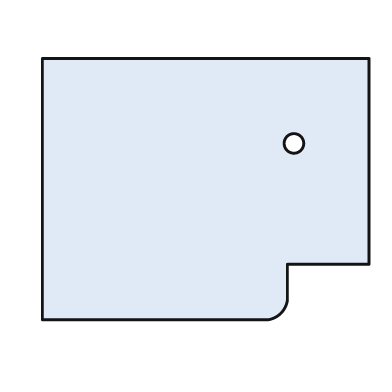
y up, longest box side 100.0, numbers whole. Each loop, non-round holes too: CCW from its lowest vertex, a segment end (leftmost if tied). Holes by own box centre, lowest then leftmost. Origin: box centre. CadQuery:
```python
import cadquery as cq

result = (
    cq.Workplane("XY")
    .moveTo(-50.0, -40.0)
    .lineTo(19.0, -40.0)
    .threePointArc((23.0, -38.0), (25.0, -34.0))
    .lineTo(25.0, -23.0)
    .lineTo(50.0, -23.0)
    .lineTo(50.0, 40.0)
    .lineTo(-50.0, 40.0)
    .close()
    .moveTo(27.0, 14.0)
    .circle(3.0)
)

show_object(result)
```